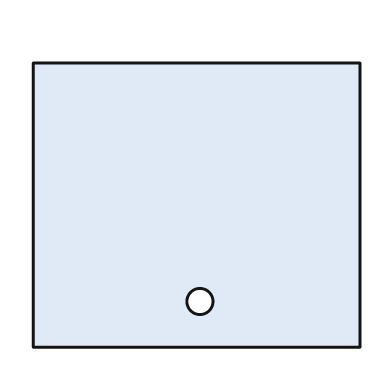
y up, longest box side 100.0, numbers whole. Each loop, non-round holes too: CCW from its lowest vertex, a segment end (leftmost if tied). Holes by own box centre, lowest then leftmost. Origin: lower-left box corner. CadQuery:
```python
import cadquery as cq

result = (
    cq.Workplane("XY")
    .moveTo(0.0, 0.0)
    .lineTo(100.0, 0.0)
    .lineTo(100.0, 87.0)
    .lineTo(0.0, 87.0)
    .close()
    .moveTo(51.0, 14.0)
    .circle(4.0)
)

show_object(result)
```